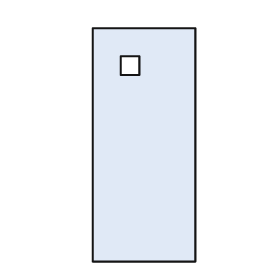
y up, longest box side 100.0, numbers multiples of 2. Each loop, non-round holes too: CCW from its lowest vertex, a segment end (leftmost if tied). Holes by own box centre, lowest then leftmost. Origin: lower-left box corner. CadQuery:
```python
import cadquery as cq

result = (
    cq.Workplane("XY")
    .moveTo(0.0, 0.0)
    .lineTo(44.0, 0.0)
    .lineTo(44.0, 100.0)
    .lineTo(0.0, 100.0)
    .close()
    .moveTo(12.0, 80.0)
    .lineTo(20.0, 80.0)
    .lineTo(20.0, 88.0)
    .lineTo(12.0, 88.0)
    .close()
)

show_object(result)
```